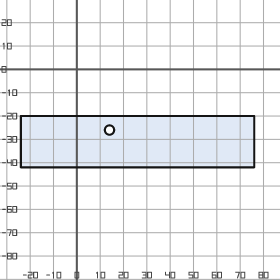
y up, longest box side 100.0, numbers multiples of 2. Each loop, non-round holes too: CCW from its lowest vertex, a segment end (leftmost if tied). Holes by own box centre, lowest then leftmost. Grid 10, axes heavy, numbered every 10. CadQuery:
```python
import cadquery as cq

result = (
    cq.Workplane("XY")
    .moveTo(-24.0, -42.0)
    .lineTo(76.0, -42.0)
    .lineTo(76.0, -20.0)
    .lineTo(-24.0, -20.0)
    .close()
    .moveTo(14.0, -26.0)
    .circle(2.0)
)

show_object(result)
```